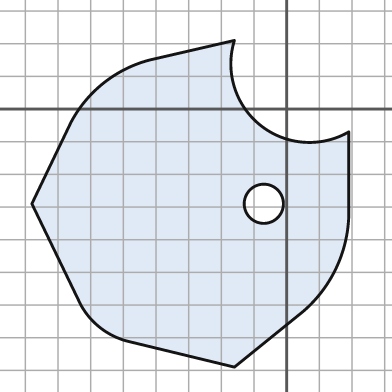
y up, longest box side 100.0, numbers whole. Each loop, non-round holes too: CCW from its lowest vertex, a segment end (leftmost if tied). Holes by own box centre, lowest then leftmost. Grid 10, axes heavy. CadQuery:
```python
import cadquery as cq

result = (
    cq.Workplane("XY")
    .moveTo(-16.0, -79.0)
    .lineTo(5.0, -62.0)
    .threePointArc((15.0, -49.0), (19.0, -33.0))
    .lineTo(19.0, -7.0)
    .threePointArc((-8.0, -5.0), (-16.0, 21.0))
    .lineTo(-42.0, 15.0)
    .threePointArc((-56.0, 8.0), (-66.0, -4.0))
    .lineTo(-78.0, -29.0)
    .lineTo(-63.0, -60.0)
    .threePointArc((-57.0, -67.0), (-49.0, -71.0))
    .close()
    .moveTo(-7.0, -29.0)
    .circle(6.0)
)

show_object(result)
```